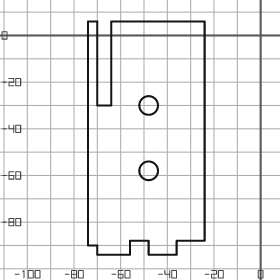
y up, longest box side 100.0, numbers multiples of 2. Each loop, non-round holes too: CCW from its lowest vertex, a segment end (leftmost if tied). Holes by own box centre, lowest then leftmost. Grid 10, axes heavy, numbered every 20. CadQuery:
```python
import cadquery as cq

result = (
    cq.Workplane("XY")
    .moveTo(-70.0, -94.0)
    .lineTo(-56.0, -94.0)
    .lineTo(-56.0, -88.0)
    .lineTo(-48.0, -88.0)
    .lineTo(-48.0, -94.0)
    .lineTo(-36.0, -94.0)
    .lineTo(-36.0, -88.0)
    .lineTo(-24.0, -88.0)
    .lineTo(-24.0, 6.0)
    .lineTo(-64.0, 6.0)
    .lineTo(-64.0, -30.0)
    .lineTo(-70.0, -30.0)
    .lineTo(-70.0, 6.0)
    .lineTo(-74.0, 6.0)
    .lineTo(-74.0, -90.0)
    .lineTo(-70.0, -90.0)
    .close()
    .moveTo(-48.0, -58.0)
    .circle(4.0)
    .moveTo(-48.0, -30.0)
    .circle(4.0)
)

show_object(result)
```